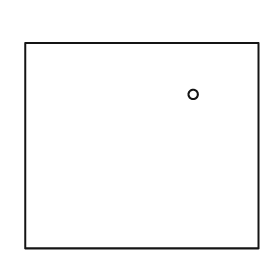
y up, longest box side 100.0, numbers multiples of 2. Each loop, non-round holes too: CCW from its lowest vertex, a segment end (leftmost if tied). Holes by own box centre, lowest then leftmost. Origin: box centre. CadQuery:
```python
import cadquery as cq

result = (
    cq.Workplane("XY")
    .moveTo(-50.0, -44.0)
    .lineTo(50.0, -44.0)
    .lineTo(50.0, 44.0)
    .lineTo(-50.0, 44.0)
    .close()
    .moveTo(22.0, 22.0)
    .circle(2.0)
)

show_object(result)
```